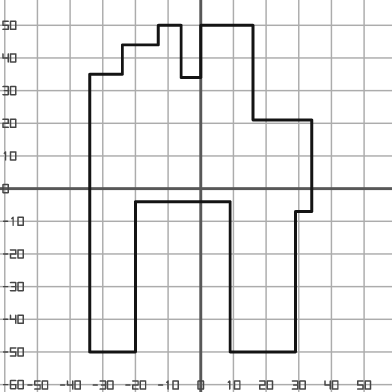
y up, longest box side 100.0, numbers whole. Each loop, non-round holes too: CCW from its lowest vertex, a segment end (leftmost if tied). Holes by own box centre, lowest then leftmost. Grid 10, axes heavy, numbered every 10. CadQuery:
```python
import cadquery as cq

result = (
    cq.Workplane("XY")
    .moveTo(-34.0, -50.0)
    .lineTo(-20.0, -50.0)
    .lineTo(-20.0, -4.0)
    .lineTo(9.0, -4.0)
    .lineTo(9.0, -50.0)
    .lineTo(29.0, -50.0)
    .lineTo(29.0, -7.0)
    .lineTo(34.0, -7.0)
    .lineTo(34.0, 21.0)
    .lineTo(16.0, 21.0)
    .lineTo(16.0, 50.0)
    .lineTo(0.0, 50.0)
    .lineTo(0.0, 34.0)
    .lineTo(-6.0, 34.0)
    .lineTo(-6.0, 50.0)
    .lineTo(-13.0, 50.0)
    .lineTo(-13.0, 44.0)
    .lineTo(-24.0, 44.0)
    .lineTo(-24.0, 35.0)
    .lineTo(-34.0, 35.0)
    .close()
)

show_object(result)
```